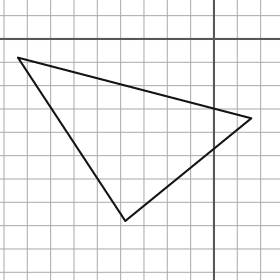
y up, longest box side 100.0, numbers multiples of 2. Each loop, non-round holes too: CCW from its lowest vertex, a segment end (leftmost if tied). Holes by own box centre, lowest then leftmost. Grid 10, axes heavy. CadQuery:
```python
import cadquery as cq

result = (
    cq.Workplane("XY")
    .moveTo(-38.0, -78.0)
    .lineTo(16.0, -34.0)
    .lineTo(-84.0, -8.0)
    .close()
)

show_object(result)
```